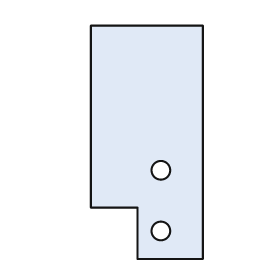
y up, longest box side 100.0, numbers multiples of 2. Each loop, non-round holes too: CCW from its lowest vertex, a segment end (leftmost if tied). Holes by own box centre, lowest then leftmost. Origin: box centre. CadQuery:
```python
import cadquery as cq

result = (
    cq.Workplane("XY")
    .moveTo(-4.0, -50.0)
    .lineTo(24.0, -50.0)
    .lineTo(24.0, 50.0)
    .lineTo(-24.0, 50.0)
    .lineTo(-24.0, -28.0)
    .lineTo(-4.0, -28.0)
    .close()
    .moveTo(6.0, -38.0)
    .circle(4.0)
    .moveTo(6.0, -12.0)
    .circle(4.0)
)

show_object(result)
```